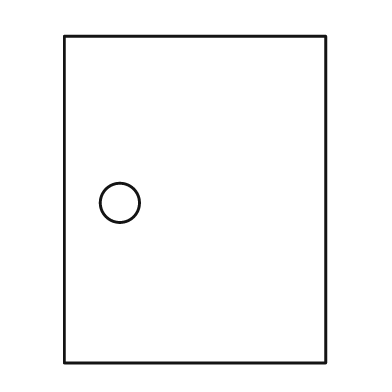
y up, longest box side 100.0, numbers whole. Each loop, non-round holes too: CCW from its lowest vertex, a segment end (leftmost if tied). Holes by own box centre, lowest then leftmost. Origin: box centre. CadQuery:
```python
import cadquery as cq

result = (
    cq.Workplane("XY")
    .moveTo(-40.0, -50.0)
    .lineTo(40.0, -50.0)
    .lineTo(40.0, 50.0)
    .lineTo(-40.0, 50.0)
    .close()
    .moveTo(-23.0, -1.0)
    .circle(6.0)
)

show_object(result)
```